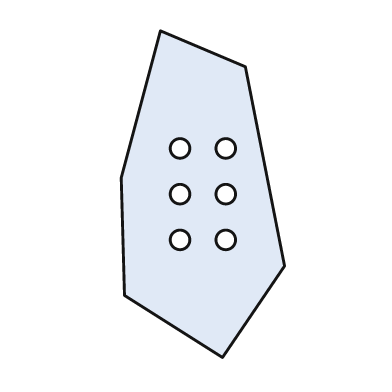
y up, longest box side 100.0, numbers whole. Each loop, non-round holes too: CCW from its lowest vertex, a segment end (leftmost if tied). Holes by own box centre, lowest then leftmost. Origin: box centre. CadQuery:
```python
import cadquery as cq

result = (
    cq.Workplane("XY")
    .moveTo(6.0, -50.0)
    .lineTo(25.0, -22.0)
    .lineTo(13.0, 39.0)
    .lineTo(-13.0, 50.0)
    .lineTo(-25.0, 5.0)
    .lineTo(-24.0, -31.0)
    .close()
    .moveTo(-7.0, -14.0)
    .circle(3.0)
    .moveTo(7.0, -14.0)
    .circle(3.0)
    .moveTo(-7.0, 0.0)
    .circle(3.0)
    .moveTo(7.0, 0.0)
    .circle(3.0)
    .moveTo(-7.0, 14.0)
    .circle(3.0)
    .moveTo(7.0, 14.0)
    .circle(3.0)
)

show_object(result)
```